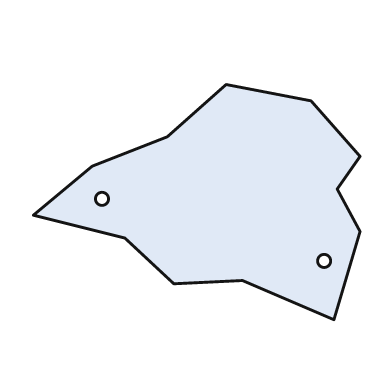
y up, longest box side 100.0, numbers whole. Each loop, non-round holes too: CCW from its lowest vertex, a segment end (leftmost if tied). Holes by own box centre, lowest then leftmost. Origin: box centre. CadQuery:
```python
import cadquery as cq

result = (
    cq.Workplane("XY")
    .moveTo(42.0, -36.0)
    .lineTo(50.0, -9.0)
    .lineTo(43.0, 4.0)
    .lineTo(50.0, 14.0)
    .lineTo(35.0, 31.0)
    .lineTo(9.0, 36.0)
    .lineTo(-9.0, 20.0)
    .lineTo(-32.0, 11.0)
    .lineTo(-50.0, -4.0)
    .lineTo(-22.0, -11.0)
    .lineTo(-7.0, -25.0)
    .lineTo(14.0, -24.0)
    .close()
    .moveTo(39.0, -18.0)
    .circle(2.0)
    .moveTo(-29.0, 1.0)
    .circle(2.0)
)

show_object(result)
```